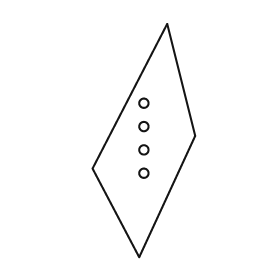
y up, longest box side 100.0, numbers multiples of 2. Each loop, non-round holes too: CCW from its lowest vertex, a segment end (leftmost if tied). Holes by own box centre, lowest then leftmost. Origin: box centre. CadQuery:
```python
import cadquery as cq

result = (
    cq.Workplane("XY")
    .moveTo(-2.0, -50.0)
    .lineTo(22.0, 2.0)
    .lineTo(10.0, 50.0)
    .lineTo(-22.0, -12.0)
    .close()
    .moveTo(0.0, -14.0)
    .circle(2.0)
    .moveTo(0.0, -4.0)
    .circle(2.0)
    .moveTo(0.0, 6.0)
    .circle(2.0)
    .moveTo(0.0, 16.0)
    .circle(2.0)
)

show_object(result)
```